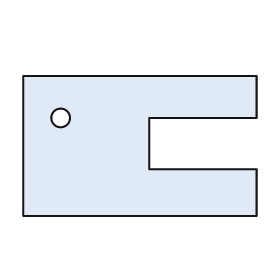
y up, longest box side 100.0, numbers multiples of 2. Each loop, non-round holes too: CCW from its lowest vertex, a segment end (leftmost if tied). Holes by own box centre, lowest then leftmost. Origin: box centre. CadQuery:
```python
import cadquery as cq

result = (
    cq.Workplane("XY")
    .moveTo(-50.0, -30.0)
    .lineTo(50.0, -30.0)
    .lineTo(50.0, -10.0)
    .lineTo(4.0, -10.0)
    .lineTo(4.0, 12.0)
    .lineTo(50.0, 12.0)
    .lineTo(50.0, 30.0)
    .lineTo(-50.0, 30.0)
    .close()
    .moveTo(-34.0, 12.0)
    .circle(4.0)
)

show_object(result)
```